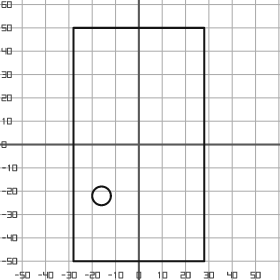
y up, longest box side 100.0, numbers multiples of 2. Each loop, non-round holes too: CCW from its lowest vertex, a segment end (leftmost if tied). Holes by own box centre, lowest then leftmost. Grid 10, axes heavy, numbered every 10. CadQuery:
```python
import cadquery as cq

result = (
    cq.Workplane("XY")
    .moveTo(-28.0, -50.0)
    .lineTo(28.0, -50.0)
    .lineTo(28.0, 50.0)
    .lineTo(-28.0, 50.0)
    .close()
    .moveTo(-16.0, -22.0)
    .circle(4.0)
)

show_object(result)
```